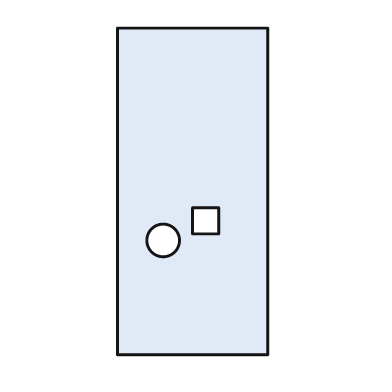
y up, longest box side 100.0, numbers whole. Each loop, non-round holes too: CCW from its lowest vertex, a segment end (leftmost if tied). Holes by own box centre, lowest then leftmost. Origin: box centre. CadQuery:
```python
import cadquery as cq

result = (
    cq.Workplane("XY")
    .moveTo(-23.0, -50.0)
    .lineTo(23.0, -50.0)
    .lineTo(23.0, 50.0)
    .lineTo(-23.0, 50.0)
    .close()
    .moveTo(-9.0, -15.0)
    .circle(5.0)
    .moveTo(0.0, -13.0)
    .lineTo(8.0, -13.0)
    .lineTo(8.0, -5.0)
    .lineTo(0.0, -5.0)
    .close()
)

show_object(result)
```